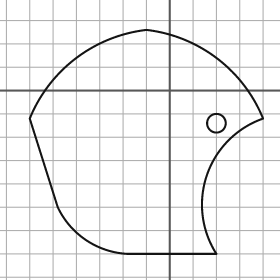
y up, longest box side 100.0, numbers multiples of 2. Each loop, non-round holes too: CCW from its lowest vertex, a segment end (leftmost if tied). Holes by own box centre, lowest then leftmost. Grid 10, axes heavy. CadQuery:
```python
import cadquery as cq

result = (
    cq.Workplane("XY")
    .moveTo(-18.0, -70.0)
    .lineTo(20.0, -70.0)
    .threePointArc((16.0, -36.0), (40.0, -12.0))
    .threePointArc((20.0, 14.0), (-10.0, 26.0))
    .threePointArc((-40.0, 14.0), (-60.0, -12.0))
    .lineTo(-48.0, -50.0)
    .threePointArc((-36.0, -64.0), (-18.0, -70.0))
    .close()
    .moveTo(20.0, -14.0)
    .circle(4.0)
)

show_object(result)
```